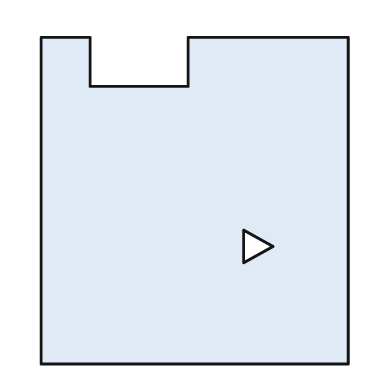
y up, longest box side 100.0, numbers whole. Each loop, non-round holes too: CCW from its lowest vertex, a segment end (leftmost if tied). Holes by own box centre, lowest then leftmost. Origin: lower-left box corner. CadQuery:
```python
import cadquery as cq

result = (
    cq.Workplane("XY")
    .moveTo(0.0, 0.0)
    .lineTo(94.0, 0.0)
    .lineTo(94.0, 100.0)
    .lineTo(45.0, 100.0)
    .lineTo(45.0, 85.0)
    .lineTo(15.0, 85.0)
    .lineTo(15.0, 100.0)
    .lineTo(0.0, 100.0)
    .close()
    .moveTo(62.0, 31.0)
    .lineTo(71.0, 36.0)
    .lineTo(62.0, 41.0)
    .close()
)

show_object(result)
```